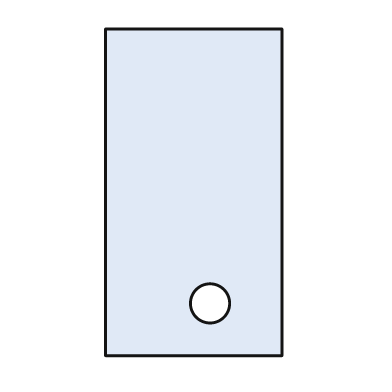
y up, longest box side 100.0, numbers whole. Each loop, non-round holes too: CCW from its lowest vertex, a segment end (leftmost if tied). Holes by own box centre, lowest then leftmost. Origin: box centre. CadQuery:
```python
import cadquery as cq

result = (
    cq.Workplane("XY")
    .moveTo(-27.0, -50.0)
    .lineTo(27.0, -50.0)
    .lineTo(27.0, 50.0)
    .lineTo(-27.0, 50.0)
    .close()
    .moveTo(5.0, -34.0)
    .circle(6.0)
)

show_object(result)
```